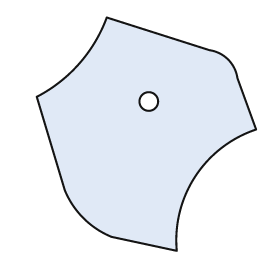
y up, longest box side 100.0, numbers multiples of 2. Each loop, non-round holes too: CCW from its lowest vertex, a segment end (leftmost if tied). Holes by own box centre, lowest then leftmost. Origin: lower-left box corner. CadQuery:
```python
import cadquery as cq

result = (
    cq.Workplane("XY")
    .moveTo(60.0, 0.0)
    .threePointArc((68.0, 32.0), (94.0, 52.0))
    .lineTo(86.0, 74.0)
    .threePointArc((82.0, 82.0), (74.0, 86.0))
    .lineTo(30.0, 100.0)
    .threePointArc((18.0, 80.0), (0.0, 66.0))
    .lineTo(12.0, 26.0)
    .threePointArc((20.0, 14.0), (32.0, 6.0))
    .close()
    .moveTo(48.0, 64.0)
    .circle(4.0)
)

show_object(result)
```